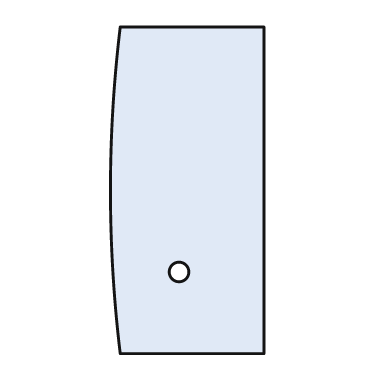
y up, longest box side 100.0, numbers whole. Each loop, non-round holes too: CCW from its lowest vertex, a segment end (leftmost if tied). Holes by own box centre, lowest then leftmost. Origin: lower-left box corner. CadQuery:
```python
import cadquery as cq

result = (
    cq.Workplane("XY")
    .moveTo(3.0, 0.0)
    .lineTo(47.0, 0.0)
    .lineTo(47.0, 100.0)
    .lineTo(3.0, 100.0)
    .threePointArc((0.0, 50.0), (3.0, 0.0))
    .close()
    .moveTo(21.0, 25.0)
    .circle(3.0)
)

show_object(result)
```